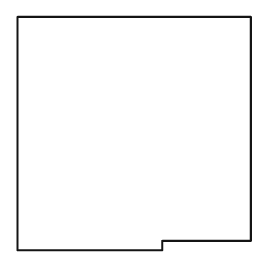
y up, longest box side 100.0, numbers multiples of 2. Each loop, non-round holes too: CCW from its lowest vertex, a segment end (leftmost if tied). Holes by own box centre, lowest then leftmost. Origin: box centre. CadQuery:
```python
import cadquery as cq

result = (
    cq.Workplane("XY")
    .moveTo(-50.0, -50.0)
    .lineTo(12.0, -50.0)
    .lineTo(12.0, -46.0)
    .lineTo(50.0, -46.0)
    .lineTo(50.0, 50.0)
    .lineTo(-50.0, 50.0)
    .close()
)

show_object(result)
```